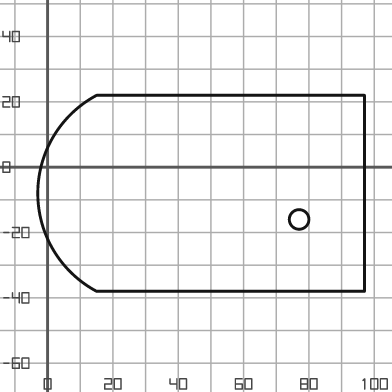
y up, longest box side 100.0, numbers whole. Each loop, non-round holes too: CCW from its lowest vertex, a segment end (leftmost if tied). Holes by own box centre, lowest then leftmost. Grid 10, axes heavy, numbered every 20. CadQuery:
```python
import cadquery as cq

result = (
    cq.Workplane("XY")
    .moveTo(15.0, -38.0)
    .lineTo(97.0, -38.0)
    .lineTo(97.0, 22.0)
    .lineTo(15.0, 22.0)
    .threePointArc((-3.0, -8.0), (15.0, -38.0))
    .close()
    .moveTo(77.0, -16.0)
    .circle(3.0)
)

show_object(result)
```